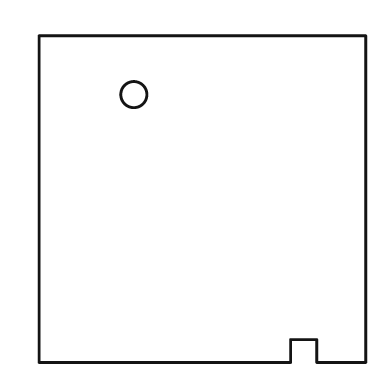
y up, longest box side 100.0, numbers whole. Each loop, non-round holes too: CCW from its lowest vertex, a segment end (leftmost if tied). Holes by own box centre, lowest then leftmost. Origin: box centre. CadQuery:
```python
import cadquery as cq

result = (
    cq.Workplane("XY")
    .moveTo(-50.0, -50.0)
    .lineTo(27.0, -50.0)
    .lineTo(27.0, -43.0)
    .lineTo(35.0, -43.0)
    .lineTo(35.0, -50.0)
    .lineTo(50.0, -50.0)
    .lineTo(50.0, 50.0)
    .lineTo(-50.0, 50.0)
    .close()
    .moveTo(-21.0, 32.0)
    .circle(4.0)
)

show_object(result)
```